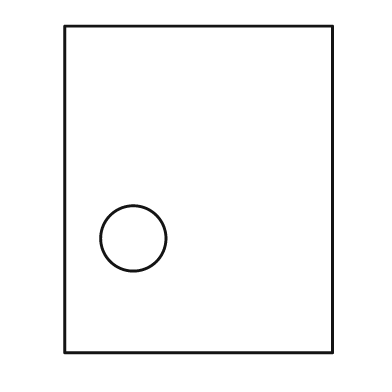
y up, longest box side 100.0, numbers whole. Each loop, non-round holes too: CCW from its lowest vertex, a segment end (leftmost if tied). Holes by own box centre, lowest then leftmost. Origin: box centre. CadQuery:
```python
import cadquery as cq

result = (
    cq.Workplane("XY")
    .moveTo(-41.0, -50.0)
    .lineTo(41.0, -50.0)
    .lineTo(41.0, 50.0)
    .lineTo(-41.0, 50.0)
    .close()
    .moveTo(-20.0, -15.0)
    .circle(10.0)
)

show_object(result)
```